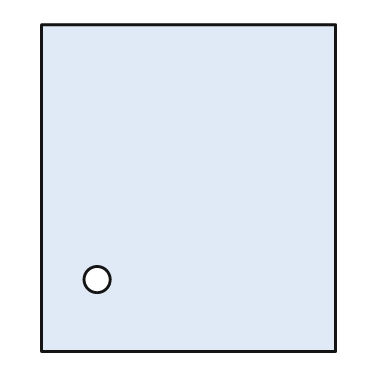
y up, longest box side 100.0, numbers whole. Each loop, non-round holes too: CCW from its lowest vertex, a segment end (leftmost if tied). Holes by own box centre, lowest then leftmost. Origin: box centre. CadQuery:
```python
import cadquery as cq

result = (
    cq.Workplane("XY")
    .moveTo(-45.0, -50.0)
    .lineTo(45.0, -50.0)
    .lineTo(45.0, 50.0)
    .lineTo(-45.0, 50.0)
    .close()
    .moveTo(-28.0, -28.0)
    .circle(4.0)
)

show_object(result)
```